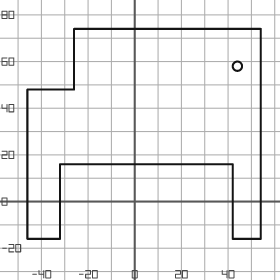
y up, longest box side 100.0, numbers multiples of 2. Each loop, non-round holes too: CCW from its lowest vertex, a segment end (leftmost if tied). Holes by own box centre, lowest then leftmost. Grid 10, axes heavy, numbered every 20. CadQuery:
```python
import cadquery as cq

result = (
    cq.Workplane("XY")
    .moveTo(-46.0, -16.0)
    .lineTo(-32.0, -16.0)
    .lineTo(-32.0, 16.0)
    .lineTo(42.0, 16.0)
    .lineTo(42.0, -16.0)
    .lineTo(54.0, -16.0)
    .lineTo(54.0, 74.0)
    .lineTo(-26.0, 74.0)
    .lineTo(-26.0, 48.0)
    .lineTo(-46.0, 48.0)
    .close()
    .moveTo(44.0, 58.0)
    .circle(2.0)
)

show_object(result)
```